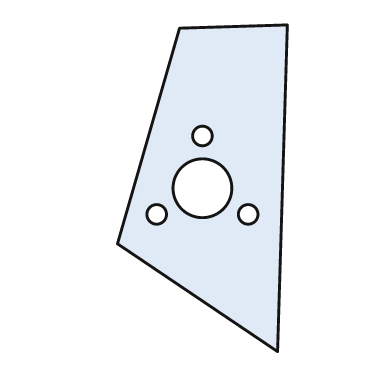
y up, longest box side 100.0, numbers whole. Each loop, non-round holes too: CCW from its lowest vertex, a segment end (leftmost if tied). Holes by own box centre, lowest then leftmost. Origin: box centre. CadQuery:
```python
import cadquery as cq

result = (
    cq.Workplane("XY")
    .moveTo(23.0, -50.0)
    .lineTo(26.0, 50.0)
    .lineTo(-7.0, 49.0)
    .lineTo(-26.0, -17.0)
    .close()
    .moveTo(-14.0, -8.0)
    .circle(3.0)
    .moveTo(14.0, -8.0)
    .circle(3.0)
    .moveTo(0.0, 0.0)
    .circle(9.0)
    .moveTo(0.0, 16.0)
    .circle(3.0)
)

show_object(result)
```